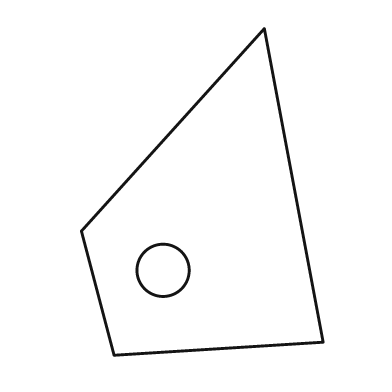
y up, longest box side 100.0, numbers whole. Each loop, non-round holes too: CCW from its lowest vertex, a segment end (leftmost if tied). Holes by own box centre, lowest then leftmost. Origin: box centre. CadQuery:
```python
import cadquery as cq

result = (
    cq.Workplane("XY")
    .moveTo(-27.0, -50.0)
    .lineTo(37.0, -46.0)
    .lineTo(19.0, 50.0)
    .lineTo(-37.0, -12.0)
    .close()
    .moveTo(-12.0, -24.0)
    .circle(8.0)
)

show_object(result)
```